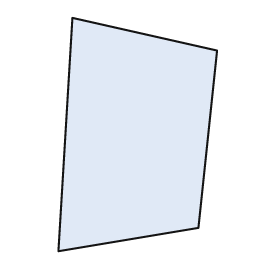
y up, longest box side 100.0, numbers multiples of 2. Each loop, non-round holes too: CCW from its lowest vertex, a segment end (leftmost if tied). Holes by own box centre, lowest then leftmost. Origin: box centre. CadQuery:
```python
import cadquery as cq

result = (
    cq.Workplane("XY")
    .moveTo(-34.0, -50.0)
    .lineTo(26.0, -40.0)
    .lineTo(34.0, 36.0)
    .lineTo(-28.0, 50.0)
    .close()
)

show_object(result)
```